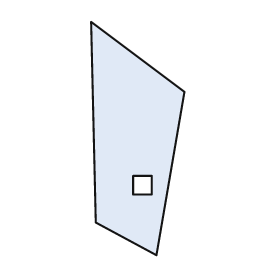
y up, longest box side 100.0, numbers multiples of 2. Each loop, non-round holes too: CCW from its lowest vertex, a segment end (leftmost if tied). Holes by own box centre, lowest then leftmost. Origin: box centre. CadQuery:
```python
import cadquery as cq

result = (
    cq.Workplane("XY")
    .moveTo(8.0, -50.0)
    .lineTo(20.0, 20.0)
    .lineTo(-20.0, 50.0)
    .lineTo(-18.0, -36.0)
    .close()
    .moveTo(-2.0, -24.0)
    .lineTo(6.0, -24.0)
    .lineTo(6.0, -16.0)
    .lineTo(-2.0, -16.0)
    .close()
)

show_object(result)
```